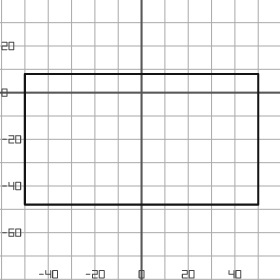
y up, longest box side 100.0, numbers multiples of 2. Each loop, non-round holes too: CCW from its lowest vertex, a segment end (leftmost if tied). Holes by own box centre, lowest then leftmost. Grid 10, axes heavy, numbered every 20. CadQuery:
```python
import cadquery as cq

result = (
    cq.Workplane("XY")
    .moveTo(-50.0, -48.0)
    .lineTo(50.0, -48.0)
    .lineTo(50.0, 8.0)
    .lineTo(-50.0, 8.0)
    .close()
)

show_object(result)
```